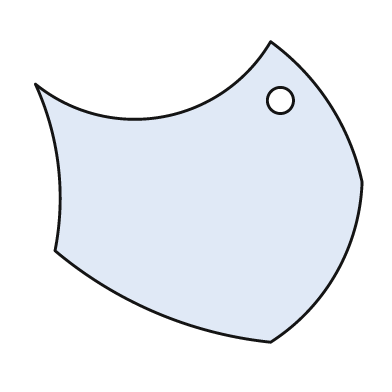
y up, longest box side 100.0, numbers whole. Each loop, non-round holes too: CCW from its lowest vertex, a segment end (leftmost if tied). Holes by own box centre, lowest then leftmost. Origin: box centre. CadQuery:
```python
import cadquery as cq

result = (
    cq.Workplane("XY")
    .moveTo(22.0, -46.0)
    .threePointArc((42.0, -25.0), (50.0, 3.0))
    .threePointArc((40.0, 27.0), (22.0, 46.0))
    .threePointArc((-11.0, 23.0), (-50.0, 33.0))
    .threePointArc((-43.0, 8.0), (-44.0, -18.0))
    .threePointArc((-13.0, -37.0), (22.0, -46.0))
    .close()
    .moveTo(25.0, 28.0)
    .circle(4.0)
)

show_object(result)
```